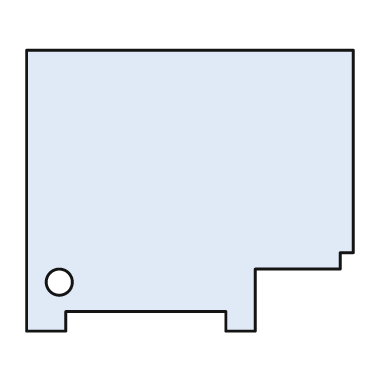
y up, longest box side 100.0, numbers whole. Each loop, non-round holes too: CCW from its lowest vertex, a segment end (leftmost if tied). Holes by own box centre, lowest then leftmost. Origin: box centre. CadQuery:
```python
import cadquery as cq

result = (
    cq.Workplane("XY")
    .moveTo(-50.0, -43.0)
    .lineTo(-38.0, -43.0)
    .lineTo(-38.0, -37.0)
    .lineTo(11.0, -37.0)
    .lineTo(11.0, -43.0)
    .lineTo(20.0, -43.0)
    .lineTo(20.0, -24.0)
    .lineTo(46.0, -24.0)
    .lineTo(46.0, -19.0)
    .lineTo(50.0, -19.0)
    .lineTo(50.0, 43.0)
    .lineTo(-50.0, 43.0)
    .close()
    .moveTo(-40.0, -28.0)
    .circle(4.0)
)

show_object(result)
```